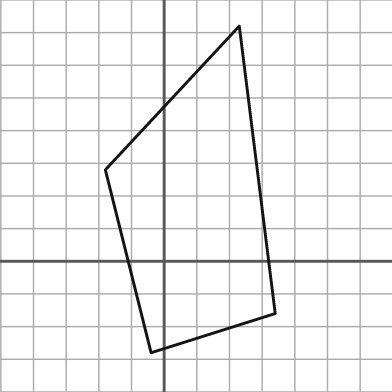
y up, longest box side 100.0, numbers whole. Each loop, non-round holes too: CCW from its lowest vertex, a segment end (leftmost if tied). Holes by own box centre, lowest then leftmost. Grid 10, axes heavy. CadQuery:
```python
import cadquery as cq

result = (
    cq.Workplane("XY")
    .moveTo(-4.0, -28.0)
    .lineTo(34.0, -16.0)
    .lineTo(23.0, 72.0)
    .lineTo(-18.0, 28.0)
    .close()
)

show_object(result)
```